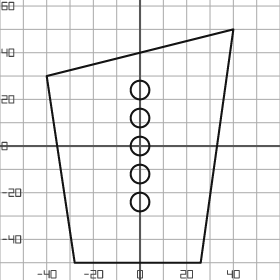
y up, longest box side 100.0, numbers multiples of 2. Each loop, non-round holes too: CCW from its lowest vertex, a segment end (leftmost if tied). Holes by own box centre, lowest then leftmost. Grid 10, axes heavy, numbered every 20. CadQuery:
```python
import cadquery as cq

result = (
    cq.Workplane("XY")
    .moveTo(-28.0, -50.0)
    .lineTo(26.0, -50.0)
    .lineTo(40.0, 50.0)
    .lineTo(-40.0, 30.0)
    .close()
    .moveTo(0.0, -24.0)
    .circle(4.0)
    .moveTo(0.0, -12.0)
    .circle(4.0)
    .moveTo(0.0, 0.0)
    .circle(4.0)
    .moveTo(0.0, 12.0)
    .circle(4.0)
    .moveTo(0.0, 24.0)
    .circle(4.0)
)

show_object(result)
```